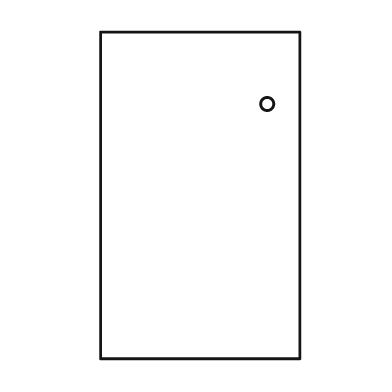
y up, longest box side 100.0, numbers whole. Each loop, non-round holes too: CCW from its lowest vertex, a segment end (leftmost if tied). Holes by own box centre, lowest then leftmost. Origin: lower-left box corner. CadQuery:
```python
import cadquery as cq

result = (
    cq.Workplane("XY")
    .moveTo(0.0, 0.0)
    .lineTo(61.0, 0.0)
    .lineTo(61.0, 100.0)
    .lineTo(0.0, 100.0)
    .close()
    .moveTo(51.0, 78.0)
    .circle(2.0)
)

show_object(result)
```